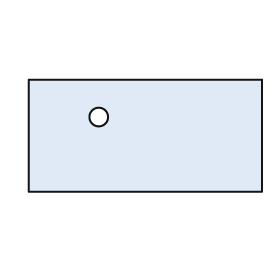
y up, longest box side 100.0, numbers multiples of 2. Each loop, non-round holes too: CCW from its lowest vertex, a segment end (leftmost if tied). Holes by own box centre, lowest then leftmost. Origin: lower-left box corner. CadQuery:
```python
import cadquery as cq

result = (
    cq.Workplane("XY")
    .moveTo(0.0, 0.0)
    .lineTo(100.0, 0.0)
    .lineTo(100.0, 48.0)
    .lineTo(0.0, 48.0)
    .close()
    .moveTo(30.0, 32.0)
    .circle(4.0)
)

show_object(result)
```